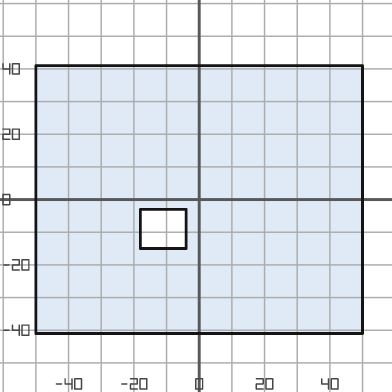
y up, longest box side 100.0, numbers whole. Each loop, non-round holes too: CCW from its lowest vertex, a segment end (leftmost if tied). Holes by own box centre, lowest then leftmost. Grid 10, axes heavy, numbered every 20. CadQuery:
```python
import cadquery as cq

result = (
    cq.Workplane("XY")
    .moveTo(-50.0, -41.0)
    .lineTo(50.0, -41.0)
    .lineTo(50.0, 41.0)
    .lineTo(-50.0, 41.0)
    .close()
    .moveTo(-18.0, -15.0)
    .lineTo(-4.0, -15.0)
    .lineTo(-4.0, -3.0)
    .lineTo(-18.0, -3.0)
    .close()
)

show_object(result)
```